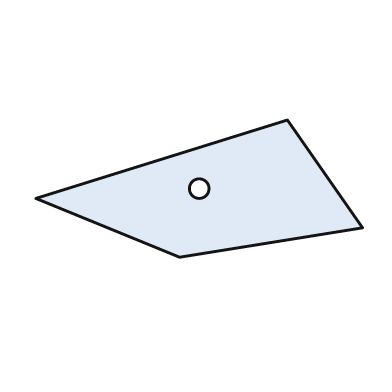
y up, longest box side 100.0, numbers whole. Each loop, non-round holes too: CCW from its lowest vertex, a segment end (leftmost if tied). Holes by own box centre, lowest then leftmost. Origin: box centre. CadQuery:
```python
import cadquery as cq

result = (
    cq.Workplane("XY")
    .moveTo(-6.0, -21.0)
    .lineTo(50.0, -12.0)
    .lineTo(27.0, 21.0)
    .lineTo(-50.0, -3.0)
    .close()
    .moveTo(0.0, 0.0)
    .circle(3.0)
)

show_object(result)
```